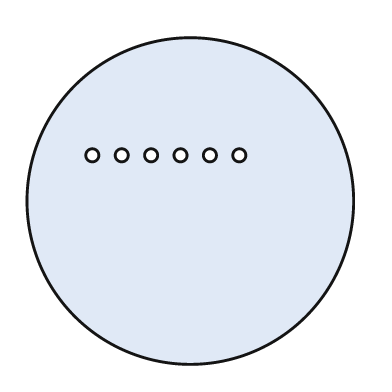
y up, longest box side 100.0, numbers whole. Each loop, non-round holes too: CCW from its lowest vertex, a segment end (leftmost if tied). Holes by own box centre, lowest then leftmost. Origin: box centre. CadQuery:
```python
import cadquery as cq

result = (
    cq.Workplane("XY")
    .moveTo(0.0, 0.0)
    .circle(50.0)
    .moveTo(-30.0, 14.0)
    .circle(2.0)
    .moveTo(-21.0, 14.0)
    .circle(2.0)
    .moveTo(-12.0, 14.0)
    .circle(2.0)
    .moveTo(-3.0, 14.0)
    .circle(2.0)
    .moveTo(6.0, 14.0)
    .circle(2.0)
    .moveTo(15.0, 14.0)
    .circle(2.0)
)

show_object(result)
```